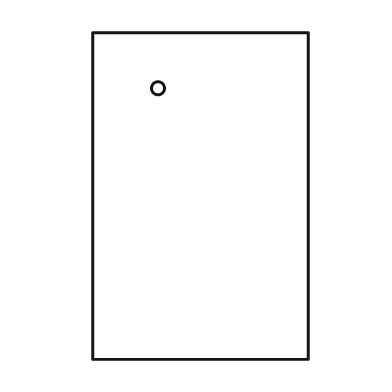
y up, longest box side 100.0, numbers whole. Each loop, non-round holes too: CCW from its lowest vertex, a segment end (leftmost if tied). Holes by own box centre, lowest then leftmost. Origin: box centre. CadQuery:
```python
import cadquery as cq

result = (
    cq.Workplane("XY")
    .moveTo(-33.0, -50.0)
    .lineTo(33.0, -50.0)
    .lineTo(33.0, 50.0)
    .lineTo(-33.0, 50.0)
    .close()
    .moveTo(-13.0, 33.0)
    .circle(2.0)
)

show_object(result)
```